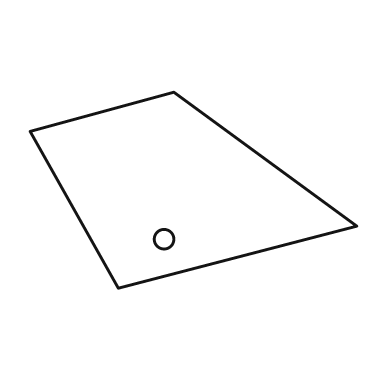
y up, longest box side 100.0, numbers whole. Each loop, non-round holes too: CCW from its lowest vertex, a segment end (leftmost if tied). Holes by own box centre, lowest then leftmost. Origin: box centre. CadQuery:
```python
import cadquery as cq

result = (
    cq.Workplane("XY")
    .moveTo(-23.0, -30.0)
    .lineTo(50.0, -11.0)
    .lineTo(-6.0, 30.0)
    .lineTo(-50.0, 18.0)
    .close()
    .moveTo(-9.0, -15.0)
    .circle(3.0)
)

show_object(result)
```